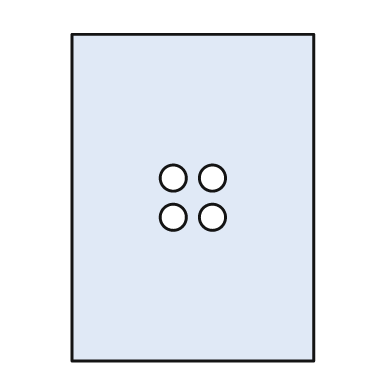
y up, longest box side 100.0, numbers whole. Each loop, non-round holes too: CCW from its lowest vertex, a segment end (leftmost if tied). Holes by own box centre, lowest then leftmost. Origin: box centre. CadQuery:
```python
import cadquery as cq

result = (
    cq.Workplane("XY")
    .moveTo(-37.0, -50.0)
    .lineTo(37.0, -50.0)
    .lineTo(37.0, 50.0)
    .lineTo(-37.0, 50.0)
    .close()
    .moveTo(-6.0, -6.0)
    .circle(4.0)
    .moveTo(6.0, -6.0)
    .circle(4.0)
    .moveTo(-6.0, 6.0)
    .circle(4.0)
    .moveTo(6.0, 6.0)
    .circle(4.0)
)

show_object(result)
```